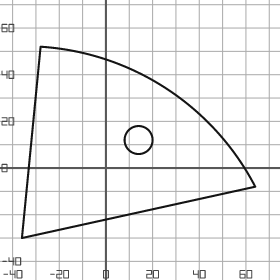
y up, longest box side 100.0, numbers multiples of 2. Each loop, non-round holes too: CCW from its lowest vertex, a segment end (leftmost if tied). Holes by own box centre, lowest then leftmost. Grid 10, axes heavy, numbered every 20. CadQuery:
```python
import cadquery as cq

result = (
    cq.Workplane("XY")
    .moveTo(-36.0, -30.0)
    .lineTo(64.0, -8.0)
    .threePointArc((26.0, 34.0), (-28.0, 52.0))
    .close()
    .moveTo(14.0, 12.0)
    .circle(6.0)
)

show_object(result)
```